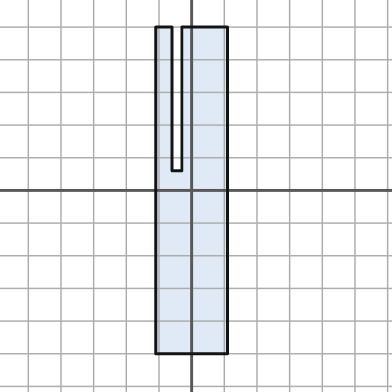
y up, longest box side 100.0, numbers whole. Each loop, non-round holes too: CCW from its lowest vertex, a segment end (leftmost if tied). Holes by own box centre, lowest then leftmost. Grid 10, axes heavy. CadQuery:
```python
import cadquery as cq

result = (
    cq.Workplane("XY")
    .moveTo(-11.0, -50.0)
    .lineTo(11.0, -50.0)
    .lineTo(11.0, 50.0)
    .lineTo(-3.0, 50.0)
    .lineTo(-3.0, 6.0)
    .lineTo(-6.0, 6.0)
    .lineTo(-6.0, 50.0)
    .lineTo(-11.0, 50.0)
    .close()
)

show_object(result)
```